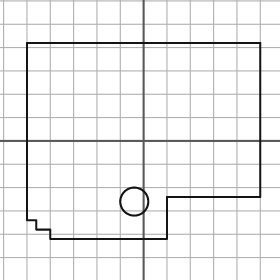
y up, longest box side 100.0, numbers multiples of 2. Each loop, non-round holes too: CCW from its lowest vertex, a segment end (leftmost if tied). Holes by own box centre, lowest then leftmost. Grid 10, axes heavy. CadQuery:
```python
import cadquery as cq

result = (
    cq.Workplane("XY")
    .moveTo(-40.0, -42.0)
    .lineTo(10.0, -42.0)
    .lineTo(10.0, -24.0)
    .lineTo(50.0, -24.0)
    .lineTo(50.0, 42.0)
    .lineTo(-50.0, 42.0)
    .lineTo(-50.0, -34.0)
    .lineTo(-46.0, -34.0)
    .lineTo(-46.0, -38.0)
    .lineTo(-40.0, -38.0)
    .close()
    .moveTo(-4.0, -26.0)
    .circle(6.0)
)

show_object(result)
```